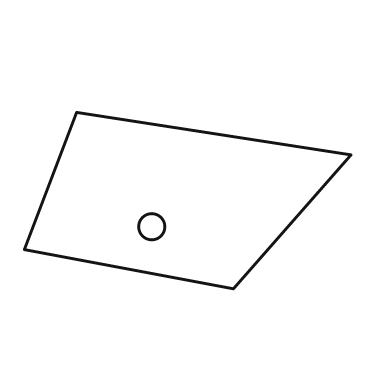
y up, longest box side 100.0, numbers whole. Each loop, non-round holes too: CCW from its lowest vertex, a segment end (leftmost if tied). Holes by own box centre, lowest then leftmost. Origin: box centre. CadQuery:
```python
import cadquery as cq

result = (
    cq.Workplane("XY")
    .moveTo(14.0, -27.0)
    .lineTo(50.0, 14.0)
    .lineTo(-34.0, 27.0)
    .lineTo(-50.0, -15.0)
    .close()
    .moveTo(-11.0, -8.0)
    .circle(4.0)
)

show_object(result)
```